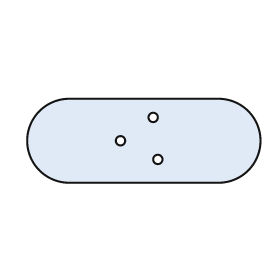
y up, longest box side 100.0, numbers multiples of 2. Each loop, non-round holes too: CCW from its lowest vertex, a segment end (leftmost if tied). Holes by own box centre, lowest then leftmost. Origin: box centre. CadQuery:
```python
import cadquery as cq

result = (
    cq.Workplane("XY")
    .moveTo(-32.0, -18.0)
    .lineTo(32.0, -18.0)
    .threePointArc((50.0, 0.0), (32.0, 18.0))
    .lineTo(-32.0, 18.0)
    .threePointArc((-50.0, 0.0), (-32.0, -18.0))
    .close()
    .moveTo(6.0, -8.0)
    .circle(2.0)
    .moveTo(-10.0, 0.0)
    .circle(2.0)
    .moveTo(4.0, 10.0)
    .circle(2.0)
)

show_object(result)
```